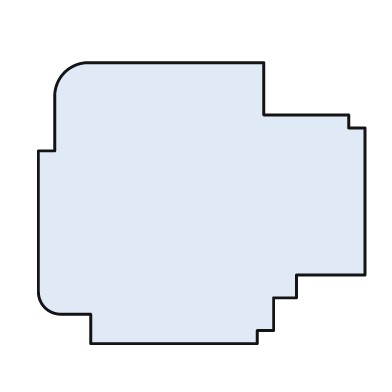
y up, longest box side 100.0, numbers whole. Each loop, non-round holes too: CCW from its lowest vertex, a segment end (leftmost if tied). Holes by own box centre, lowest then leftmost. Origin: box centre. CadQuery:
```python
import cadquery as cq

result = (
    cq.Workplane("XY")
    .moveTo(-34.0, -43.0)
    .lineTo(17.0, -43.0)
    .lineTo(17.0, -39.0)
    .lineTo(22.0, -39.0)
    .lineTo(22.0, -29.0)
    .lineTo(29.0, -29.0)
    .lineTo(29.0, -22.0)
    .lineTo(50.0, -22.0)
    .lineTo(50.0, 23.0)
    .lineTo(45.0, 23.0)
    .lineTo(45.0, 27.0)
    .lineTo(19.0, 27.0)
    .lineTo(19.0, 43.0)
    .lineTo(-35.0, 43.0)
    .threePointArc((-42.0, 40.0), (-45.0, 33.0))
    .lineTo(-45.0, 16.0)
    .lineTo(-50.0, 16.0)
    .lineTo(-50.0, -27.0)
    .threePointArc((-48.0, -32.0), (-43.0, -34.0))
    .lineTo(-34.0, -34.0)
    .close()
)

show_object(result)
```